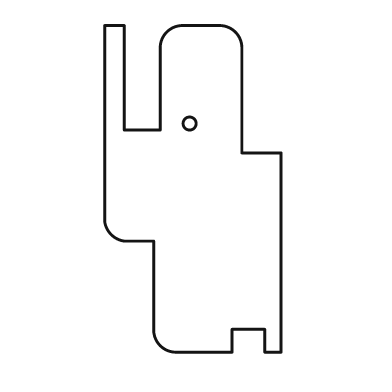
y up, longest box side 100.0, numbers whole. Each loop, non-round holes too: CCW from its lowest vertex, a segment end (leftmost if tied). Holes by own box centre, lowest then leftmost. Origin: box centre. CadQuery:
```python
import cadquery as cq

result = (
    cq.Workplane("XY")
    .moveTo(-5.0, -50.0)
    .lineTo(12.0, -50.0)
    .lineTo(12.0, -43.0)
    .lineTo(22.0, -43.0)
    .lineTo(22.0, -50.0)
    .lineTo(27.0, -50.0)
    .lineTo(27.0, 11.0)
    .lineTo(15.0, 11.0)
    .lineTo(15.0, 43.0)
    .threePointArc((13.0, 48.0), (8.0, 50.0))
    .lineTo(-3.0, 50.0)
    .threePointArc((-8.0, 48.0), (-10.0, 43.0))
    .lineTo(-10.0, 18.0)
    .lineTo(-21.0, 18.0)
    .lineTo(-21.0, 50.0)
    .lineTo(-27.0, 50.0)
    .lineTo(-27.0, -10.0)
    .threePointArc((-25.0, -14.0), (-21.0, -16.0))
    .lineTo(-12.0, -16.0)
    .lineTo(-12.0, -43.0)
    .threePointArc((-10.0, -48.0), (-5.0, -50.0))
    .close()
    .moveTo(-1.0, 20.0)
    .circle(2.0)
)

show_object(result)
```